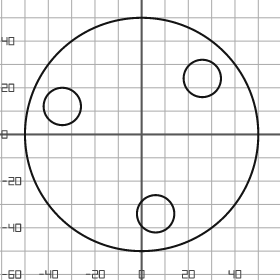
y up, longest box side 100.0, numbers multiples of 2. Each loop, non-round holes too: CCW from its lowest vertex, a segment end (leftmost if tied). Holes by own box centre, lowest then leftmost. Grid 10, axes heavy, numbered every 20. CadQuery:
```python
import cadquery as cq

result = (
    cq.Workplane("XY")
    .moveTo(0.0, 0.0)
    .circle(50.0)
    .moveTo(6.0, -34.0)
    .circle(8.0)
    .moveTo(-34.0, 12.0)
    .circle(8.0)
    .moveTo(26.0, 24.0)
    .circle(8.0)
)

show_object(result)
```